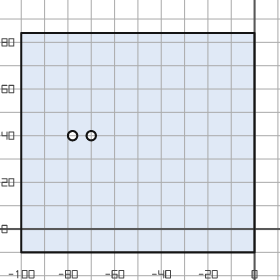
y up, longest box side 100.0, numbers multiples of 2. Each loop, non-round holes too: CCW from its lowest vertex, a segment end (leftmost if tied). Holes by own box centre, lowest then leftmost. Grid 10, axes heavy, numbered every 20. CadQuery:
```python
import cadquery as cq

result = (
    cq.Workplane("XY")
    .moveTo(-100.0, -10.0)
    .lineTo(0.0, -10.0)
    .lineTo(0.0, 84.0)
    .lineTo(-100.0, 84.0)
    .close()
    .moveTo(-78.0, 40.0)
    .circle(2.0)
    .moveTo(-70.0, 40.0)
    .circle(2.0)
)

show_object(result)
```